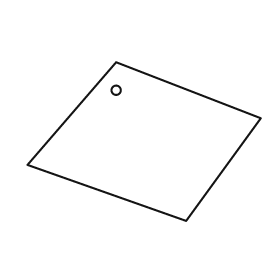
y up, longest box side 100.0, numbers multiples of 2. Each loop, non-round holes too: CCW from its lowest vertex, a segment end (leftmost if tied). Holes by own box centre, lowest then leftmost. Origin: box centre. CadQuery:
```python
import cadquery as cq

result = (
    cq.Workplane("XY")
    .moveTo(18.0, -34.0)
    .lineTo(50.0, 10.0)
    .lineTo(-12.0, 34.0)
    .lineTo(-50.0, -10.0)
    .close()
    .moveTo(-12.0, 22.0)
    .circle(2.0)
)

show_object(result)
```